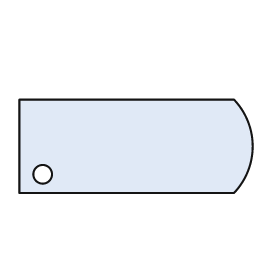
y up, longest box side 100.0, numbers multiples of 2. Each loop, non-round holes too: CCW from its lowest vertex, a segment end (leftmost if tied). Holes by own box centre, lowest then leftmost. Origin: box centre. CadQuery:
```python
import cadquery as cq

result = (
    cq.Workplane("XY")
    .moveTo(-50.0, -20.0)
    .lineTo(42.0, -20.0)
    .threePointArc((50.0, 0.0), (42.0, 20.0))
    .lineTo(-50.0, 20.0)
    .close()
    .moveTo(-40.0, -12.0)
    .circle(4.0)
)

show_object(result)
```